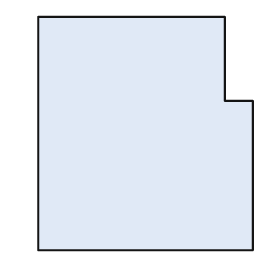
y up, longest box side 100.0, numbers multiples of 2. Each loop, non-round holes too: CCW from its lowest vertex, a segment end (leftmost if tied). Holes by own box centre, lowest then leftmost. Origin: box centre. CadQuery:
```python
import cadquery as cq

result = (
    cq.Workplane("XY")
    .moveTo(-46.0, -50.0)
    .lineTo(46.0, -50.0)
    .lineTo(46.0, 14.0)
    .lineTo(34.0, 14.0)
    .lineTo(34.0, 50.0)
    .lineTo(-46.0, 50.0)
    .close()
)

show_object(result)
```